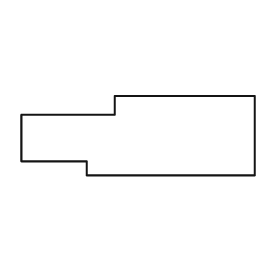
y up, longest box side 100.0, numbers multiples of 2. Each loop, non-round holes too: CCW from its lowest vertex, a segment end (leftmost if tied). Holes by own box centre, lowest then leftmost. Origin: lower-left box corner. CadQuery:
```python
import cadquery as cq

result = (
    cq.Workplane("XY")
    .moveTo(28.0, 0.0)
    .lineTo(100.0, 0.0)
    .lineTo(100.0, 34.0)
    .lineTo(40.0, 34.0)
    .lineTo(40.0, 26.0)
    .lineTo(0.0, 26.0)
    .lineTo(0.0, 6.0)
    .lineTo(28.0, 6.0)
    .close()
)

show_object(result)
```